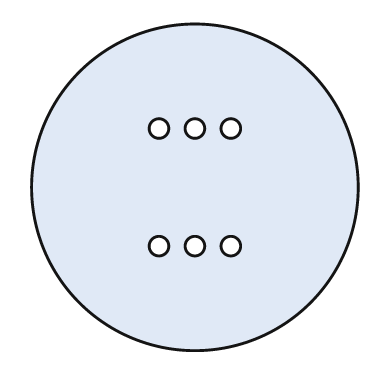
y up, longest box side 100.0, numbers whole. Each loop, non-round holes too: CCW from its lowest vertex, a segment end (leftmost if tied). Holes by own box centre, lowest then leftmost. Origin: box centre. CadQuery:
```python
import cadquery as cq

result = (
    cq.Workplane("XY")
    .moveTo(0.0, 0.0)
    .circle(50.0)
    .moveTo(-11.0, -18.0)
    .circle(3.0)
    .moveTo(0.0, -18.0)
    .circle(3.0)
    .moveTo(11.0, -18.0)
    .circle(3.0)
    .moveTo(-11.0, 18.0)
    .circle(3.0)
    .moveTo(0.0, 18.0)
    .circle(3.0)
    .moveTo(11.0, 18.0)
    .circle(3.0)
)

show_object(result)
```